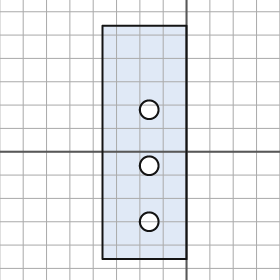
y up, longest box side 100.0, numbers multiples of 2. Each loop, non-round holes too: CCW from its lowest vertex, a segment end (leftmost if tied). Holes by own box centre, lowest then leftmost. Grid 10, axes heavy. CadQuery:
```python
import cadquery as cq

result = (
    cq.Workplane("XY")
    .moveTo(-36.0, -46.0)
    .lineTo(0.0, -46.0)
    .lineTo(0.0, 54.0)
    .lineTo(-36.0, 54.0)
    .close()
    .moveTo(-16.0, -30.0)
    .circle(4.0)
    .moveTo(-16.0, -6.0)
    .circle(4.0)
    .moveTo(-16.0, 18.0)
    .circle(4.0)
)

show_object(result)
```